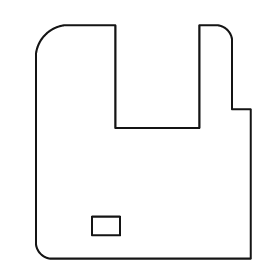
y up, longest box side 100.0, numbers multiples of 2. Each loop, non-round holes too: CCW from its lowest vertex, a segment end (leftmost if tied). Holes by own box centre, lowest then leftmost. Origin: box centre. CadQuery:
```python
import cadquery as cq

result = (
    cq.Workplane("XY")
    .moveTo(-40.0, -50.0)
    .lineTo(46.0, -50.0)
    .lineTo(46.0, 14.0)
    .lineTo(38.0, 14.0)
    .lineTo(38.0, 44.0)
    .threePointArc((36.0, 48.0), (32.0, 50.0))
    .lineTo(24.0, 50.0)
    .lineTo(24.0, 6.0)
    .lineTo(-12.0, 6.0)
    .lineTo(-12.0, 50.0)
    .lineTo(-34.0, 50.0)
    .threePointArc((-42.0, 46.0), (-46.0, 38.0))
    .lineTo(-46.0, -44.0)
    .threePointArc((-44.0, -48.0), (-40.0, -50.0))
    .close()
    .moveTo(-22.0, -40.0)
    .lineTo(-10.0, -40.0)
    .lineTo(-10.0, -32.0)
    .lineTo(-22.0, -32.0)
    .close()
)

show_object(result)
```